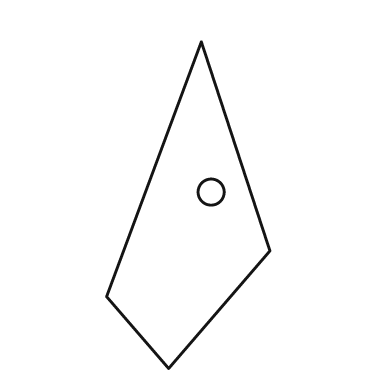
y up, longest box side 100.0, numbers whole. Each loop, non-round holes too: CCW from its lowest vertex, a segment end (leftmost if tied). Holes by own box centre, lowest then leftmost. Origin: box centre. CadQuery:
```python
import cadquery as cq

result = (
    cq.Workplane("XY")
    .moveTo(-6.0, -50.0)
    .lineTo(25.0, -14.0)
    .lineTo(4.0, 50.0)
    .lineTo(-25.0, -28.0)
    .close()
    .moveTo(7.0, 4.0)
    .circle(4.0)
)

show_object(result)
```